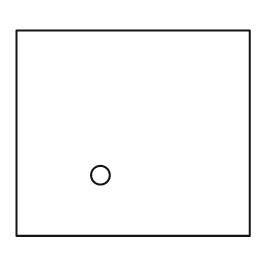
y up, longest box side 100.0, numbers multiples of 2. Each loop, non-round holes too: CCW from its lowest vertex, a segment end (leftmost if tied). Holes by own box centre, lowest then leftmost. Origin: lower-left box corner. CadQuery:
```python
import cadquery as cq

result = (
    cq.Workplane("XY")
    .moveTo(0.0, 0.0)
    .lineTo(100.0, 0.0)
    .lineTo(100.0, 88.0)
    .lineTo(0.0, 88.0)
    .close()
    .moveTo(36.0, 26.0)
    .circle(4.0)
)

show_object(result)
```